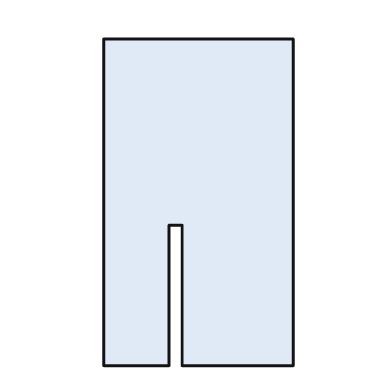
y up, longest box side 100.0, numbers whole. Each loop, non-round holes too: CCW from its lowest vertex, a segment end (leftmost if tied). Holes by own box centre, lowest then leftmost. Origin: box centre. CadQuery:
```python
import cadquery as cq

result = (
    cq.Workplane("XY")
    .moveTo(-29.0, -50.0)
    .lineTo(-9.0, -50.0)
    .lineTo(-9.0, -7.0)
    .lineTo(-5.0, -7.0)
    .lineTo(-5.0, -50.0)
    .lineTo(29.0, -50.0)
    .lineTo(29.0, 50.0)
    .lineTo(-29.0, 50.0)
    .close()
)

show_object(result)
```